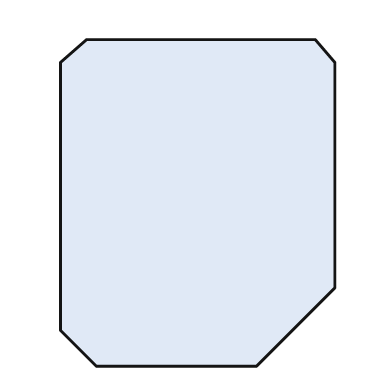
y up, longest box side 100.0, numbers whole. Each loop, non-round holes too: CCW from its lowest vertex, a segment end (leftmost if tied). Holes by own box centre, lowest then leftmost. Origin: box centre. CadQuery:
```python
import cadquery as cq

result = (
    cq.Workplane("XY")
    .moveTo(-31.0, -50.0)
    .lineTo(18.0, -50.0)
    .lineTo(42.0, -26.0)
    .lineTo(42.0, 43.0)
    .lineTo(36.0, 50.0)
    .lineTo(-34.0, 50.0)
    .lineTo(-42.0, 43.0)
    .lineTo(-42.0, -39.0)
    .close()
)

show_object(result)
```